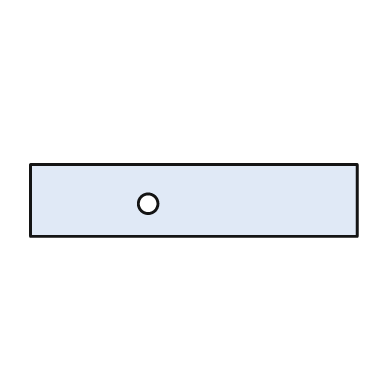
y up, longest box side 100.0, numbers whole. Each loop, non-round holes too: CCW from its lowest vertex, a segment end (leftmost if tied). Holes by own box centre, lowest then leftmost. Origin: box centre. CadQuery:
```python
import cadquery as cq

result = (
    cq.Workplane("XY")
    .moveTo(-50.0, -11.0)
    .lineTo(50.0, -11.0)
    .lineTo(50.0, 11.0)
    .lineTo(-50.0, 11.0)
    .close()
    .moveTo(-14.0, -1.0)
    .circle(3.0)
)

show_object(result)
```